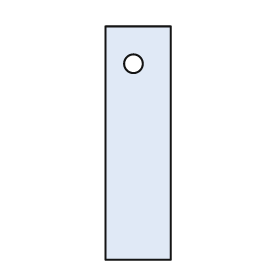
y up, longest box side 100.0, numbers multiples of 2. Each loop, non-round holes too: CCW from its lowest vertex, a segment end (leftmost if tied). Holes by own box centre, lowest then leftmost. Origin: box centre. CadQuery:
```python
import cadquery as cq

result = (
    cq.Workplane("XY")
    .moveTo(-14.0, -50.0)
    .lineTo(14.0, -50.0)
    .lineTo(14.0, 50.0)
    .lineTo(-14.0, 50.0)
    .close()
    .moveTo(-2.0, 34.0)
    .circle(4.0)
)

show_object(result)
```